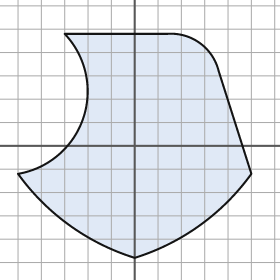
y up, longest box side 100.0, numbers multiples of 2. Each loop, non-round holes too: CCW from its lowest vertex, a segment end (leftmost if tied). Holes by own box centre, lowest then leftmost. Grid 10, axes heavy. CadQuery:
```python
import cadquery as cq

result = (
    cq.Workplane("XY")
    .moveTo(0.0, -48.0)
    .threePointArc((28.0, -34.0), (50.0, -12.0))
    .lineTo(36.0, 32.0)
    .threePointArc((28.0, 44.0), (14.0, 48.0))
    .lineTo(-30.0, 48.0)
    .threePointArc((-22.0, 12.0), (-50.0, -12.0))
    .threePointArc((-28.0, -34.0), (0.0, -48.0))
    .close()
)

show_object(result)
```